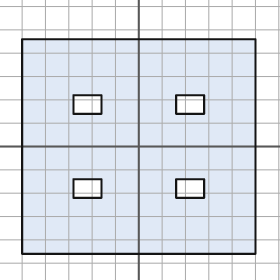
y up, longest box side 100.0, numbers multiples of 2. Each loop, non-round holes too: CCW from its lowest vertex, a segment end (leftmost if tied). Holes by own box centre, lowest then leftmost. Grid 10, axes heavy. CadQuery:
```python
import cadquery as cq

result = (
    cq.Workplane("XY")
    .moveTo(-50.0, -46.0)
    .lineTo(50.0, -46.0)
    .lineTo(50.0, 46.0)
    .lineTo(-50.0, 46.0)
    .close()
    .moveTo(-28.0, -22.0)
    .lineTo(-16.0, -22.0)
    .lineTo(-16.0, -14.0)
    .lineTo(-28.0, -14.0)
    .close()
    .moveTo(16.0, -22.0)
    .lineTo(28.0, -22.0)
    .lineTo(28.0, -14.0)
    .lineTo(16.0, -14.0)
    .close()
    .moveTo(-28.0, 14.0)
    .lineTo(-16.0, 14.0)
    .lineTo(-16.0, 22.0)
    .lineTo(-28.0, 22.0)
    .close()
    .moveTo(16.0, 14.0)
    .lineTo(28.0, 14.0)
    .lineTo(28.0, 22.0)
    .lineTo(16.0, 22.0)
    .close()
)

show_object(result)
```